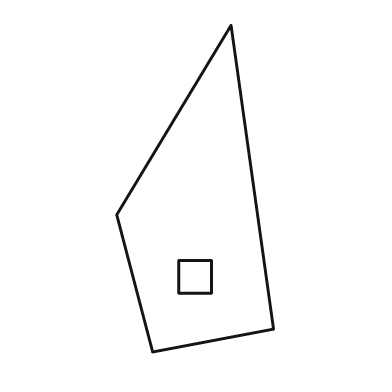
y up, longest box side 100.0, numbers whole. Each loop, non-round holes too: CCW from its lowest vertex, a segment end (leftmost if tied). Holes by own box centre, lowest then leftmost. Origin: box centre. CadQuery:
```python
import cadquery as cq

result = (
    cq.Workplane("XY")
    .moveTo(-13.0, -50.0)
    .lineTo(24.0, -43.0)
    .lineTo(11.0, 50.0)
    .lineTo(-24.0, -8.0)
    .close()
    .moveTo(-5.0, -32.0)
    .lineTo(5.0, -32.0)
    .lineTo(5.0, -22.0)
    .lineTo(-5.0, -22.0)
    .close()
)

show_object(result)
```